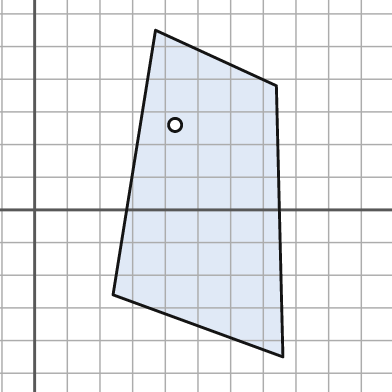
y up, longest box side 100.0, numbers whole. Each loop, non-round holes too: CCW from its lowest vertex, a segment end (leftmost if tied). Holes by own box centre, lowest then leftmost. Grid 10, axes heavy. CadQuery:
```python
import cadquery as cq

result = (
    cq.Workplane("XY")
    .moveTo(76.0, -45.0)
    .lineTo(74.0, 38.0)
    .lineTo(37.0, 55.0)
    .lineTo(24.0, -26.0)
    .close()
    .moveTo(43.0, 26.0)
    .circle(2.0)
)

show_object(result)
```